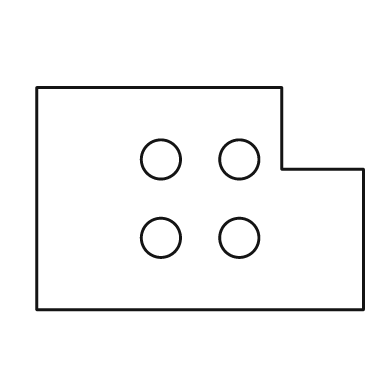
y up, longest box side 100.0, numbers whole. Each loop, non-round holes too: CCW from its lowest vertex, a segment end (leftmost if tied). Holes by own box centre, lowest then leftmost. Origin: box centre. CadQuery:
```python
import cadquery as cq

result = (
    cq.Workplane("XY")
    .moveTo(-50.0, -34.0)
    .lineTo(50.0, -34.0)
    .lineTo(50.0, 9.0)
    .lineTo(25.0, 9.0)
    .lineTo(25.0, 34.0)
    .lineTo(-50.0, 34.0)
    .close()
    .moveTo(-12.0, -12.0)
    .circle(6.0)
    .moveTo(12.0, -12.0)
    .circle(6.0)
    .moveTo(-12.0, 12.0)
    .circle(6.0)
    .moveTo(12.0, 12.0)
    .circle(6.0)
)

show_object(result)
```